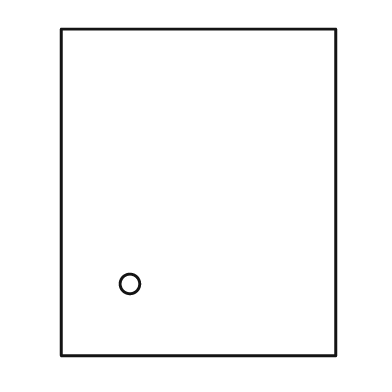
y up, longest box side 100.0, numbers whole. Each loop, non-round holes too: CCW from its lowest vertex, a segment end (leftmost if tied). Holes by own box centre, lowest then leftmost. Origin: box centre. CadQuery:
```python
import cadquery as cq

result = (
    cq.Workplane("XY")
    .moveTo(-42.0, -50.0)
    .lineTo(42.0, -50.0)
    .lineTo(42.0, 50.0)
    .lineTo(-42.0, 50.0)
    .close()
    .moveTo(-21.0, -28.0)
    .circle(3.0)
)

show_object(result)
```